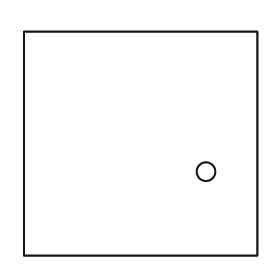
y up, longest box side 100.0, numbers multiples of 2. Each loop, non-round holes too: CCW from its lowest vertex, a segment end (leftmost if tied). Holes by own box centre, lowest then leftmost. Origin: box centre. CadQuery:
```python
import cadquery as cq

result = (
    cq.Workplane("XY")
    .moveTo(-50.0, -48.0)
    .lineTo(50.0, -48.0)
    .lineTo(50.0, 48.0)
    .lineTo(-50.0, 48.0)
    .close()
    .moveTo(28.0, -12.0)
    .circle(4.0)
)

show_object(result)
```